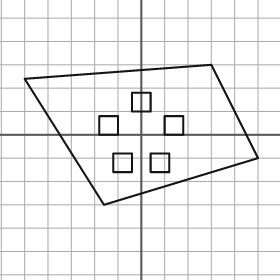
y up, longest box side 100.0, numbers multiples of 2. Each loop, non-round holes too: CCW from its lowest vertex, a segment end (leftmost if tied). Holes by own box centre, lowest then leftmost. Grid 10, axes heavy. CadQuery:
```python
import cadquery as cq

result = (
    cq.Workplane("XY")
    .moveTo(-16.0, -30.0)
    .lineTo(50.0, -10.0)
    .lineTo(30.0, 30.0)
    .lineTo(-50.0, 24.0)
    .close()
    .moveTo(-12.0, -16.0)
    .lineTo(-4.0, -16.0)
    .lineTo(-4.0, -8.0)
    .lineTo(-12.0, -8.0)
    .close()
    .moveTo(4.0, -16.0)
    .lineTo(12.0, -16.0)
    .lineTo(12.0, -8.0)
    .lineTo(4.0, -8.0)
    .close()
    .moveTo(-18.0, 0.0)
    .lineTo(-10.0, 0.0)
    .lineTo(-10.0, 8.0)
    .lineTo(-18.0, 8.0)
    .close()
    .moveTo(10.0, 0.0)
    .lineTo(18.0, 0.0)
    .lineTo(18.0, 8.0)
    .lineTo(10.0, 8.0)
    .close()
    .moveTo(-4.0, 10.0)
    .lineTo(4.0, 10.0)
    .lineTo(4.0, 18.0)
    .lineTo(-4.0, 18.0)
    .close()
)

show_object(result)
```